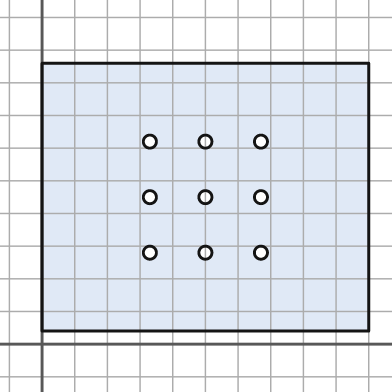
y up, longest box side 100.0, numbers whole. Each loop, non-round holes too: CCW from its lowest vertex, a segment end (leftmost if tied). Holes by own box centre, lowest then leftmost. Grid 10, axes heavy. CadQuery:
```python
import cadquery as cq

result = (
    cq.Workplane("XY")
    .moveTo(0.0, 4.0)
    .lineTo(100.0, 4.0)
    .lineTo(100.0, 86.0)
    .lineTo(0.0, 86.0)
    .close()
    .moveTo(33.0, 28.0)
    .circle(2.0)
    .moveTo(50.0, 28.0)
    .circle(2.0)
    .moveTo(67.0, 28.0)
    .circle(2.0)
    .moveTo(33.0, 45.0)
    .circle(2.0)
    .moveTo(50.0, 45.0)
    .circle(2.0)
    .moveTo(67.0, 45.0)
    .circle(2.0)
    .moveTo(33.0, 62.0)
    .circle(2.0)
    .moveTo(50.0, 62.0)
    .circle(2.0)
    .moveTo(67.0, 62.0)
    .circle(2.0)
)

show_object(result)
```